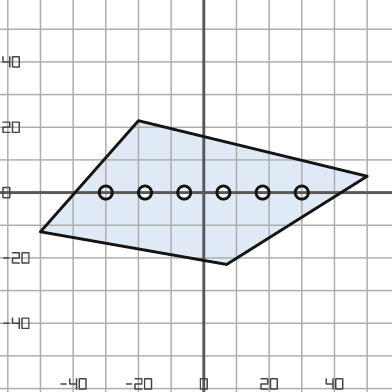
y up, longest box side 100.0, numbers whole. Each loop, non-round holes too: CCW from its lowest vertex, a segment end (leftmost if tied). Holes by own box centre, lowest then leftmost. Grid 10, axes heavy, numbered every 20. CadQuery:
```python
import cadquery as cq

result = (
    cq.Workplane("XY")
    .moveTo(7.0, -22.0)
    .lineTo(50.0, 5.0)
    .lineTo(-20.0, 22.0)
    .lineTo(-50.0, -12.0)
    .close()
    .moveTo(-30.0, 0.0)
    .circle(2.0)
    .moveTo(-18.0, 0.0)
    .circle(2.0)
    .moveTo(-6.0, 0.0)
    .circle(2.0)
    .moveTo(6.0, 0.0)
    .circle(2.0)
    .moveTo(18.0, 0.0)
    .circle(2.0)
    .moveTo(30.0, 0.0)
    .circle(2.0)
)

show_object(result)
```